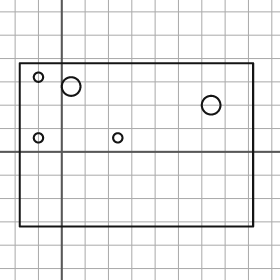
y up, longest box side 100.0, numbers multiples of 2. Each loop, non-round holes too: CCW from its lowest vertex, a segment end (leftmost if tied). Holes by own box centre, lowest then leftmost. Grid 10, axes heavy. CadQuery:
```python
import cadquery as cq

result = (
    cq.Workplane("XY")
    .moveTo(-18.0, -32.0)
    .lineTo(82.0, -32.0)
    .lineTo(82.0, 38.0)
    .lineTo(-18.0, 38.0)
    .close()
    .moveTo(-10.0, 6.0)
    .circle(2.0)
    .moveTo(24.0, 6.0)
    .circle(2.0)
    .moveTo(64.0, 20.0)
    .circle(4.0)
    .moveTo(4.0, 28.0)
    .circle(4.0)
    .moveTo(-10.0, 32.0)
    .circle(2.0)
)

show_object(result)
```